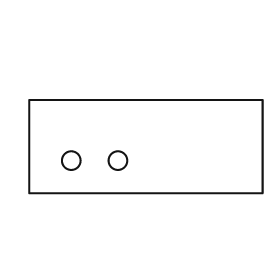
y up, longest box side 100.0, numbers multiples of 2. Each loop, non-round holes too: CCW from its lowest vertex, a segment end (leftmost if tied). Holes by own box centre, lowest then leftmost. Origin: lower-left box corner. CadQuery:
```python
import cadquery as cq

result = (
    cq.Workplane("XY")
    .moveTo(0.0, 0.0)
    .lineTo(100.0, 0.0)
    .lineTo(100.0, 40.0)
    .lineTo(0.0, 40.0)
    .close()
    .moveTo(18.0, 14.0)
    .circle(4.0)
    .moveTo(38.0, 14.0)
    .circle(4.0)
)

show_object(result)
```